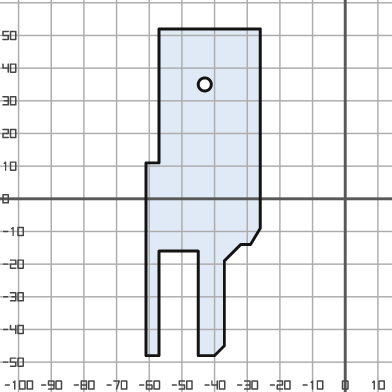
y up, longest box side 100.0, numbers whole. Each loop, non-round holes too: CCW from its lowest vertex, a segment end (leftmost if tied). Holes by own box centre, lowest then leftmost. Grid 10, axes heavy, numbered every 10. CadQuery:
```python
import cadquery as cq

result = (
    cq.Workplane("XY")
    .moveTo(-61.0, -48.0)
    .lineTo(-57.0, -48.0)
    .lineTo(-57.0, -16.0)
    .lineTo(-45.0, -16.0)
    .lineTo(-45.0, -48.0)
    .lineTo(-40.0, -48.0)
    .lineTo(-37.0, -45.0)
    .lineTo(-37.0, -19.0)
    .lineTo(-32.0, -14.0)
    .lineTo(-29.0, -14.0)
    .lineTo(-26.0, -9.0)
    .lineTo(-26.0, 52.0)
    .lineTo(-57.0, 52.0)
    .lineTo(-57.0, 11.0)
    .lineTo(-61.0, 11.0)
    .close()
    .moveTo(-43.0, 35.0)
    .circle(2.0)
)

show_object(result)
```